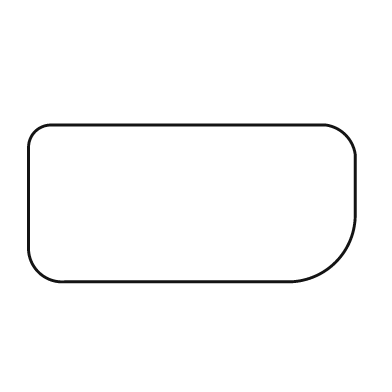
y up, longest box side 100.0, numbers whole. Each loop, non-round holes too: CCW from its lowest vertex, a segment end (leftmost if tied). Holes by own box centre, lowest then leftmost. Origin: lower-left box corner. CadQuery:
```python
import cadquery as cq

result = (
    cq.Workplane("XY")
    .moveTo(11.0, 0.0)
    .lineTo(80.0, 0.0)
    .threePointArc((94.0, 6.0), (100.0, 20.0))
    .lineTo(100.0, 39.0)
    .threePointArc((97.0, 45.0), (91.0, 48.0))
    .lineTo(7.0, 48.0)
    .threePointArc((2.0, 46.0), (0.0, 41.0))
    .lineTo(0.0, 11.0)
    .threePointArc((3.0, 3.0), (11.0, 0.0))
    .close()
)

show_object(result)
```